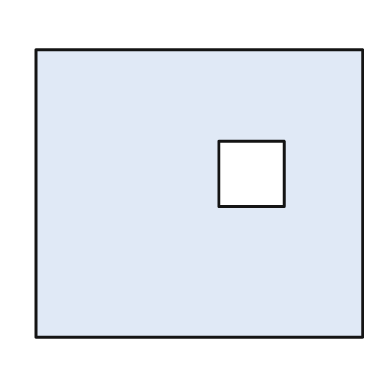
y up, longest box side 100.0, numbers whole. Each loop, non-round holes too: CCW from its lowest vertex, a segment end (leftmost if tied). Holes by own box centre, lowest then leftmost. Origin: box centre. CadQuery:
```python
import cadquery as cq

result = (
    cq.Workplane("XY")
    .moveTo(-50.0, -44.0)
    .lineTo(50.0, -44.0)
    .lineTo(50.0, 44.0)
    .lineTo(-50.0, 44.0)
    .close()
    .moveTo(6.0, -4.0)
    .lineTo(26.0, -4.0)
    .lineTo(26.0, 16.0)
    .lineTo(6.0, 16.0)
    .close()
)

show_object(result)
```